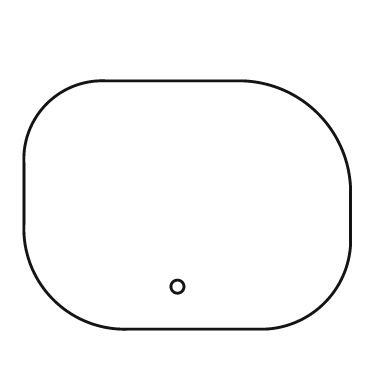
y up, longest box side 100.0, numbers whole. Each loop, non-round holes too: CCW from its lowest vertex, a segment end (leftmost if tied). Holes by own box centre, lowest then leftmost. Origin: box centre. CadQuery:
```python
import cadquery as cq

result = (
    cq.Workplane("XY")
    .moveTo(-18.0, -38.0)
    .lineTo(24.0, -38.0)
    .threePointArc((42.0, -30.0), (50.0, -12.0))
    .lineTo(50.0, 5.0)
    .threePointArc((40.0, 28.0), (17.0, 38.0))
    .lineTo(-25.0, 38.0)
    .threePointArc((-43.0, 31.0), (-50.0, 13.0))
    .lineTo(-50.0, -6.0)
    .threePointArc((-41.0, -29.0), (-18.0, -38.0))
    .close()
    .moveTo(-3.0, -25.0)
    .circle(2.0)
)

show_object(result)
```